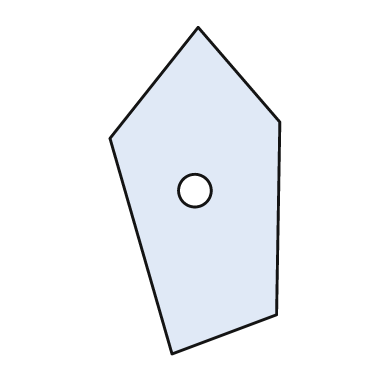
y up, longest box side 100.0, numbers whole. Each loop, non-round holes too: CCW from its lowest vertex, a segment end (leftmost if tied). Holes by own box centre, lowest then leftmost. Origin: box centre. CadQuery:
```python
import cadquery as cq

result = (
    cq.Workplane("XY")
    .moveTo(-7.0, -50.0)
    .lineTo(25.0, -38.0)
    .lineTo(26.0, 21.0)
    .lineTo(1.0, 50.0)
    .lineTo(-26.0, 16.0)
    .close()
    .moveTo(0.0, 0.0)
    .circle(5.0)
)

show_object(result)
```